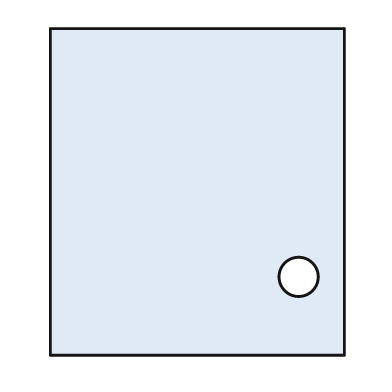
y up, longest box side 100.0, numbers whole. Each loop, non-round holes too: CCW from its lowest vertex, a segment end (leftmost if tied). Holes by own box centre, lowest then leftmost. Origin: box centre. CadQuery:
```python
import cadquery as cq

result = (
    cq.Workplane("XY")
    .moveTo(-45.0, -50.0)
    .lineTo(45.0, -50.0)
    .lineTo(45.0, 50.0)
    .lineTo(-45.0, 50.0)
    .close()
    .moveTo(31.0, -26.0)
    .circle(6.0)
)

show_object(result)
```